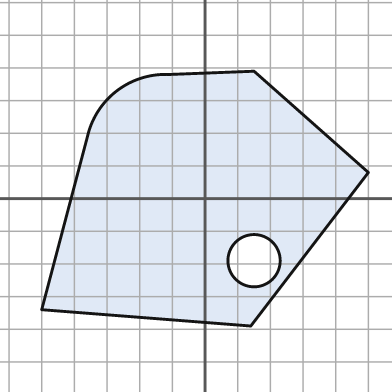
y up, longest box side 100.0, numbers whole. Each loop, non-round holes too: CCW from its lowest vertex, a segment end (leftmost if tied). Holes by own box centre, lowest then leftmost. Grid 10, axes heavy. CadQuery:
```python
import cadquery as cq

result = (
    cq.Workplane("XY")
    .moveTo(14.0, -39.0)
    .lineTo(50.0, 8.0)
    .lineTo(15.0, 39.0)
    .lineTo(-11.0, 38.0)
    .threePointArc((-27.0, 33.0), (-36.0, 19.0))
    .lineTo(-50.0, -34.0)
    .close()
    .moveTo(15.0, -19.0)
    .circle(8.0)
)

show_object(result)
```